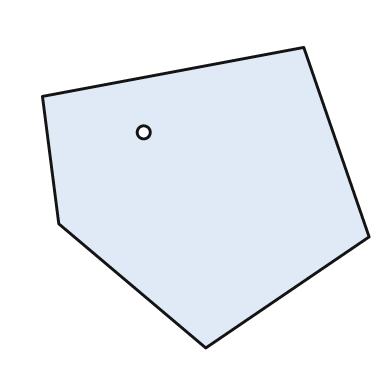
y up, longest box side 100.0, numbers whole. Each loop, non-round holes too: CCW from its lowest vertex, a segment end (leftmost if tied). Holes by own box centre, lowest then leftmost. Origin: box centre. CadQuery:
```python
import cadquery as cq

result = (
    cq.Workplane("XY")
    .moveTo(0.0, -46.0)
    .lineTo(50.0, -12.0)
    .lineTo(30.0, 46.0)
    .lineTo(-50.0, 31.0)
    .lineTo(-45.0, -8.0)
    .close()
    .moveTo(-19.0, 20.0)
    .circle(2.0)
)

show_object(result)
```